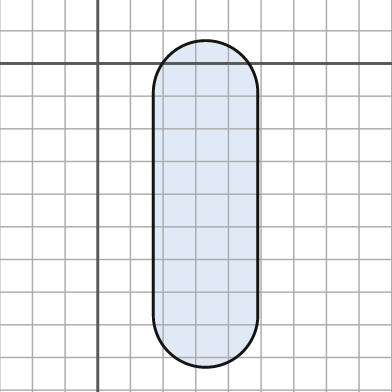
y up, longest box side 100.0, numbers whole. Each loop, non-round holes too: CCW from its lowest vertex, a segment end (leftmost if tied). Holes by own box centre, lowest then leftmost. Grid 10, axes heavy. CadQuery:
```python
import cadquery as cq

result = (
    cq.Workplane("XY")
    .moveTo(17.0, -77.0)
    .threePointArc((33.0, -93.0), (49.0, -77.0))
    .lineTo(49.0, -9.0)
    .threePointArc((33.0, 7.0), (17.0, -9.0))
    .close()
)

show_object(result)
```